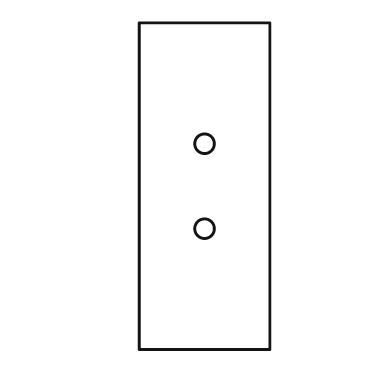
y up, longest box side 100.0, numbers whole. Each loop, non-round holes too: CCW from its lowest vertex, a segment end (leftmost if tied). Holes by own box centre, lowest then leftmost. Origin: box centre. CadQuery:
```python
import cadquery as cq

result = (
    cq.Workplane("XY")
    .moveTo(-20.0, -50.0)
    .lineTo(20.0, -50.0)
    .lineTo(20.0, 50.0)
    .lineTo(-20.0, 50.0)
    .close()
    .moveTo(0.0, -13.0)
    .circle(3.0)
    .moveTo(0.0, 13.0)
    .circle(3.0)
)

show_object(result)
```